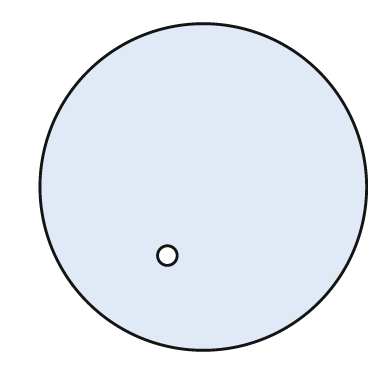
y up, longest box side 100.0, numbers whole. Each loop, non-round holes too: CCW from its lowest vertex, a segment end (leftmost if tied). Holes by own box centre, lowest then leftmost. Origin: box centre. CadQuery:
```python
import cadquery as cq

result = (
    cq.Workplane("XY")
    .moveTo(0.0, 0.0)
    .circle(50.0)
    .moveTo(-11.0, -21.0)
    .circle(3.0)
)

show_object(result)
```